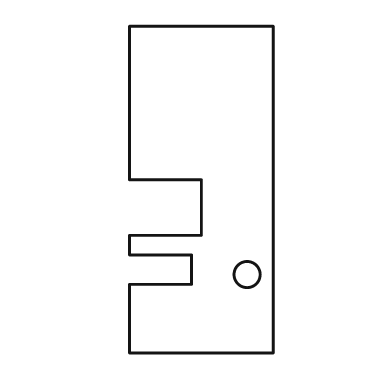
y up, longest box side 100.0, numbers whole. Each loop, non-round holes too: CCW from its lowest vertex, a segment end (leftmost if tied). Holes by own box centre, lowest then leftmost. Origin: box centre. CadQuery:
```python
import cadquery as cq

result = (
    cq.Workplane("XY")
    .moveTo(-22.0, -50.0)
    .lineTo(22.0, -50.0)
    .lineTo(22.0, 50.0)
    .lineTo(-22.0, 50.0)
    .lineTo(-22.0, 3.0)
    .lineTo(0.0, 3.0)
    .lineTo(0.0, -14.0)
    .lineTo(-22.0, -14.0)
    .lineTo(-22.0, -20.0)
    .lineTo(-3.0, -20.0)
    .lineTo(-3.0, -29.0)
    .lineTo(-22.0, -29.0)
    .close()
    .moveTo(14.0, -26.0)
    .circle(4.0)
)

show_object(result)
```